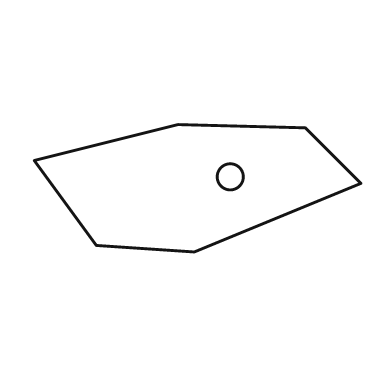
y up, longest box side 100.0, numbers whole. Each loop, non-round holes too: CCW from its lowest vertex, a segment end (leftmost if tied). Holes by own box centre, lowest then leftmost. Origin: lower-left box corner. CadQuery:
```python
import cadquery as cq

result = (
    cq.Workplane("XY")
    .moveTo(49.0, 0.0)
    .lineTo(100.0, 21.0)
    .lineTo(83.0, 38.0)
    .lineTo(44.0, 39.0)
    .lineTo(0.0, 28.0)
    .lineTo(19.0, 2.0)
    .close()
    .moveTo(60.0, 23.0)
    .circle(4.0)
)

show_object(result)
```